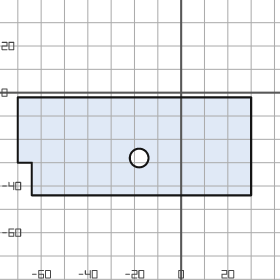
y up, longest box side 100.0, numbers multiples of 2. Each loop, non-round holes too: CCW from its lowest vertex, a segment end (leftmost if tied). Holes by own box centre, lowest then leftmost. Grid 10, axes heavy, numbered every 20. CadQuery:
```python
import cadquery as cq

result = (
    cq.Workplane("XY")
    .moveTo(-64.0, -44.0)
    .lineTo(30.0, -44.0)
    .lineTo(30.0, -2.0)
    .lineTo(-70.0, -2.0)
    .lineTo(-70.0, -30.0)
    .lineTo(-64.0, -30.0)
    .close()
    .moveTo(-18.0, -28.0)
    .circle(4.0)
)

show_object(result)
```